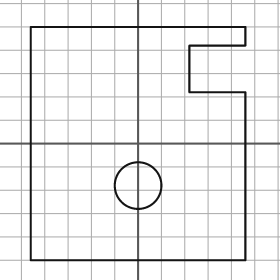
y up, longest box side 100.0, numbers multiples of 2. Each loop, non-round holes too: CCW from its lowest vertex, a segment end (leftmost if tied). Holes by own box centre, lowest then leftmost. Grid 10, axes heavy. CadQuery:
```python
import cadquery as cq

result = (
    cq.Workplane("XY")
    .moveTo(-46.0, -50.0)
    .lineTo(46.0, -50.0)
    .lineTo(46.0, 22.0)
    .lineTo(22.0, 22.0)
    .lineTo(22.0, 42.0)
    .lineTo(46.0, 42.0)
    .lineTo(46.0, 50.0)
    .lineTo(-46.0, 50.0)
    .close()
    .moveTo(0.0, -18.0)
    .circle(10.0)
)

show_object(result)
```